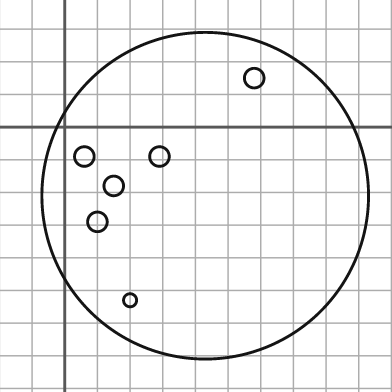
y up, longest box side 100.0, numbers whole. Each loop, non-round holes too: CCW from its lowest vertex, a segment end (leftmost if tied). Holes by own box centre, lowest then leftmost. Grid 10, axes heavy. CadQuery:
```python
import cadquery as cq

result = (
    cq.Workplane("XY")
    .moveTo(43.0, -21.0)
    .circle(50.0)
    .moveTo(20.0, -53.0)
    .circle(2.0)
    .moveTo(10.0, -29.0)
    .circle(3.0)
    .moveTo(15.0, -18.0)
    .circle(3.0)
    .moveTo(6.0, -9.0)
    .circle(3.0)
    .moveTo(29.0, -9.0)
    .circle(3.0)
    .moveTo(58.0, 15.0)
    .circle(3.0)
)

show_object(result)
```